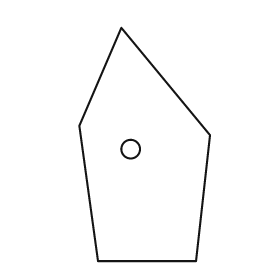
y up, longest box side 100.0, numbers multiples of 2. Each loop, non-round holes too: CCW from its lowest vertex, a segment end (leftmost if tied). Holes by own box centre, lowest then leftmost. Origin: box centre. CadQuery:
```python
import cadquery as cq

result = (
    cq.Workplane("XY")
    .moveTo(-20.0, -50.0)
    .lineTo(22.0, -50.0)
    .lineTo(28.0, 4.0)
    .lineTo(-10.0, 50.0)
    .lineTo(-28.0, 8.0)
    .close()
    .moveTo(-6.0, -2.0)
    .circle(4.0)
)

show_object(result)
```